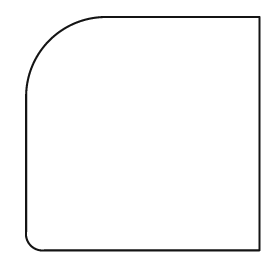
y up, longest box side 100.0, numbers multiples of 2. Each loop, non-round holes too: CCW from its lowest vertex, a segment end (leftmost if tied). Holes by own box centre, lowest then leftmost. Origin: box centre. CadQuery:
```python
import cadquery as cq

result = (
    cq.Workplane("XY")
    .moveTo(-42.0, -50.0)
    .lineTo(50.0, -50.0)
    .lineTo(50.0, 50.0)
    .lineTo(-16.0, 50.0)
    .threePointArc((-40.0, 40.0), (-50.0, 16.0))
    .lineTo(-50.0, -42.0)
    .threePointArc((-48.0, -48.0), (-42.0, -50.0))
    .close()
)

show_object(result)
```